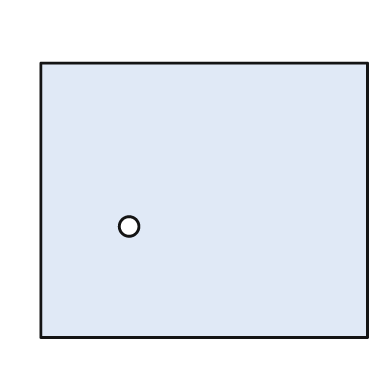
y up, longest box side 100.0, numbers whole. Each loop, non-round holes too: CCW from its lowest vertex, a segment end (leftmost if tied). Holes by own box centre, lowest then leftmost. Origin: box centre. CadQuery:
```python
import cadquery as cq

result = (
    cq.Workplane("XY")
    .moveTo(-50.0, -42.0)
    .lineTo(50.0, -42.0)
    .lineTo(50.0, 42.0)
    .lineTo(-50.0, 42.0)
    .close()
    .moveTo(-23.0, -8.0)
    .circle(3.0)
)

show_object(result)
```